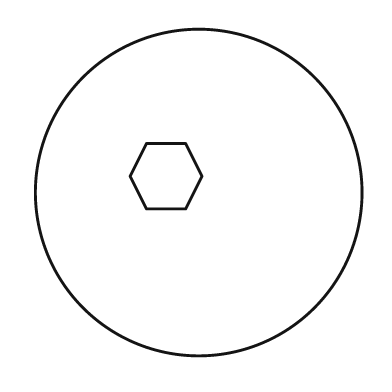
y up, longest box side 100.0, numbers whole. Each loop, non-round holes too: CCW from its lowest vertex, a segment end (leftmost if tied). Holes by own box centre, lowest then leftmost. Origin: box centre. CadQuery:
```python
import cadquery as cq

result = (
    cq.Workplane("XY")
    .moveTo(0.0, 0.0)
    .circle(50.0)
    .moveTo(-16.0, -5.0)
    .lineTo(-4.0, -5.0)
    .lineTo(1.0, 5.0)
    .lineTo(-4.0, 15.0)
    .lineTo(-16.0, 15.0)
    .lineTo(-21.0, 5.0)
    .close()
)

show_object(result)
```